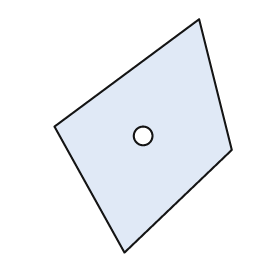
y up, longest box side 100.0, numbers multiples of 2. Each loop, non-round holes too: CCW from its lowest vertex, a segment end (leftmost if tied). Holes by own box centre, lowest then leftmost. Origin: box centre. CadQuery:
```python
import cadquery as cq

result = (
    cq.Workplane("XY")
    .moveTo(-8.0, -50.0)
    .lineTo(38.0, -6.0)
    .lineTo(24.0, 50.0)
    .lineTo(-38.0, 4.0)
    .close()
    .moveTo(0.0, 0.0)
    .circle(4.0)
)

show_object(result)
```